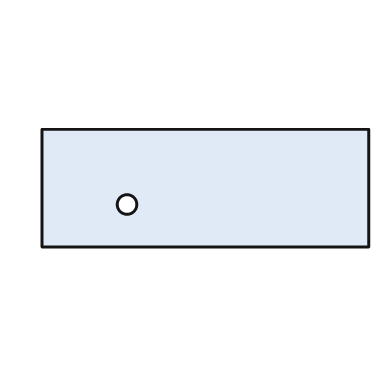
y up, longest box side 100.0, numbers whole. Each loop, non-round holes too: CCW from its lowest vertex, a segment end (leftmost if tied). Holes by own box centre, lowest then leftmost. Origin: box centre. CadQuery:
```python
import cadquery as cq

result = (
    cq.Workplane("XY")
    .moveTo(-50.0, -18.0)
    .lineTo(50.0, -18.0)
    .lineTo(50.0, 18.0)
    .lineTo(-50.0, 18.0)
    .close()
    .moveTo(-24.0, -5.0)
    .circle(3.0)
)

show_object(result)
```